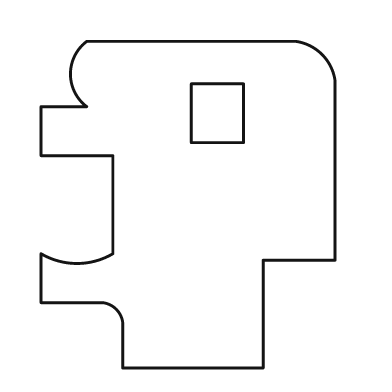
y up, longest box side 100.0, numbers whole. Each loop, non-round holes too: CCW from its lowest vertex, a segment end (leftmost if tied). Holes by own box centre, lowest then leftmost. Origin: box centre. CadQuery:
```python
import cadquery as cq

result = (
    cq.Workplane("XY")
    .moveTo(-20.0, -50.0)
    .lineTo(23.0, -50.0)
    .lineTo(23.0, -17.0)
    .lineTo(45.0, -17.0)
    .lineTo(45.0, 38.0)
    .threePointArc((41.0, 46.0), (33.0, 50.0))
    .lineTo(-31.0, 50.0)
    .threePointArc((-36.0, 40.0), (-31.0, 30.0))
    .lineTo(-45.0, 30.0)
    .lineTo(-45.0, 15.0)
    .lineTo(-23.0, 15.0)
    .lineTo(-23.0, -15.0)
    .threePointArc((-34.0, -18.0), (-45.0, -15.0))
    .lineTo(-45.0, -30.0)
    .lineTo(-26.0, -30.0)
    .threePointArc((-22.0, -32.0), (-20.0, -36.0))
    .close()
    .moveTo(1.0, 19.0)
    .lineTo(17.0, 19.0)
    .lineTo(17.0, 37.0)
    .lineTo(1.0, 37.0)
    .close()
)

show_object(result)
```